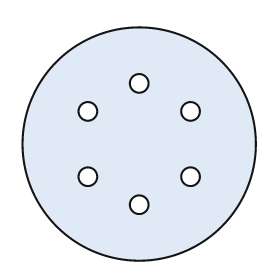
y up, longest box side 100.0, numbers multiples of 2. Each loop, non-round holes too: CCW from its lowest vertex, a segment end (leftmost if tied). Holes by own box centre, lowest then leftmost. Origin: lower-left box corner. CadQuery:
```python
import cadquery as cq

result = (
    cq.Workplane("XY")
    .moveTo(50.0, 50.0)
    .circle(50.0)
    .moveTo(50.0, 24.0)
    .circle(4.0)
    .moveTo(28.0, 36.0)
    .circle(4.0)
    .moveTo(72.0, 36.0)
    .circle(4.0)
    .moveTo(28.0, 64.0)
    .circle(4.0)
    .moveTo(72.0, 64.0)
    .circle(4.0)
    .moveTo(50.0, 76.0)
    .circle(4.0)
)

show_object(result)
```